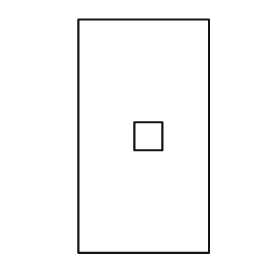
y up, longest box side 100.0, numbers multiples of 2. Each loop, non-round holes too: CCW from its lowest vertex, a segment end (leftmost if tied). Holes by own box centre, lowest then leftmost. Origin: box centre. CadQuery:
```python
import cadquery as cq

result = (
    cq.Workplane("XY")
    .moveTo(-28.0, -50.0)
    .lineTo(28.0, -50.0)
    .lineTo(28.0, 50.0)
    .lineTo(-28.0, 50.0)
    .close()
    .moveTo(-4.0, -6.0)
    .lineTo(8.0, -6.0)
    .lineTo(8.0, 6.0)
    .lineTo(-4.0, 6.0)
    .close()
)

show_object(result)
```